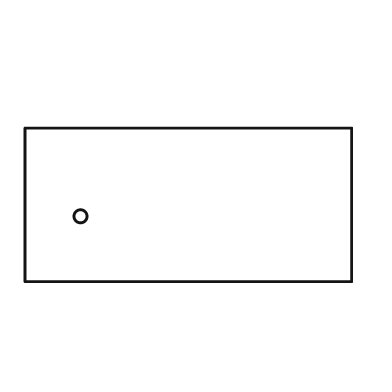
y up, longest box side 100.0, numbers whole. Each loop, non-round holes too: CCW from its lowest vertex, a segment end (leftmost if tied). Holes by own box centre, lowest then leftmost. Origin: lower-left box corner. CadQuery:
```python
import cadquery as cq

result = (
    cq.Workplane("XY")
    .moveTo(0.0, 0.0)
    .lineTo(100.0, 0.0)
    .lineTo(100.0, 47.0)
    .lineTo(0.0, 47.0)
    .close()
    .moveTo(17.0, 20.0)
    .circle(2.0)
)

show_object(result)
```